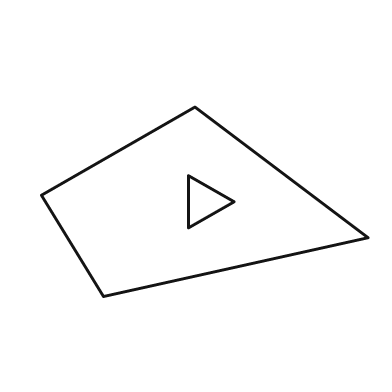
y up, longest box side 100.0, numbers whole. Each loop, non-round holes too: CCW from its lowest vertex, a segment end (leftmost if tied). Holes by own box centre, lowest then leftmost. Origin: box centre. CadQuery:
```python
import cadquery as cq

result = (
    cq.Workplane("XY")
    .moveTo(-31.0, -29.0)
    .lineTo(50.0, -11.0)
    .lineTo(-3.0, 29.0)
    .lineTo(-50.0, 2.0)
    .close()
    .moveTo(-5.0, -8.0)
    .lineTo(9.0, 0.0)
    .lineTo(-5.0, 8.0)
    .close()
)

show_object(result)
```